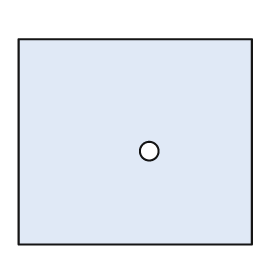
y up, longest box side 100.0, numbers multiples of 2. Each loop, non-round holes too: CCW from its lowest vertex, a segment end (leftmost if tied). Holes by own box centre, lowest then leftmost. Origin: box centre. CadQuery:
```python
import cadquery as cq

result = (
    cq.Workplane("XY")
    .moveTo(-50.0, -44.0)
    .lineTo(50.0, -44.0)
    .lineTo(50.0, 44.0)
    .lineTo(-50.0, 44.0)
    .close()
    .moveTo(6.0, -4.0)
    .circle(4.0)
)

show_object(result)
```